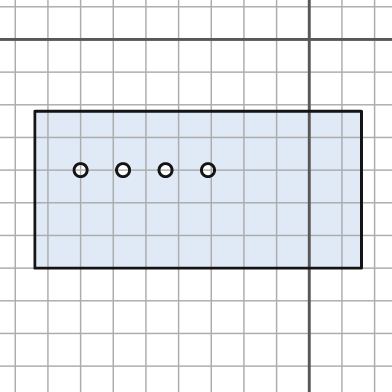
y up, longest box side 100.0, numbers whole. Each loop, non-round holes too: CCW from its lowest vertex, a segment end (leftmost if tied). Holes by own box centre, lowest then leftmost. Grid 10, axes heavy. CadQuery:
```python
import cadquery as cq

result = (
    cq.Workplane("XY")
    .moveTo(-84.0, -70.0)
    .lineTo(16.0, -70.0)
    .lineTo(16.0, -22.0)
    .lineTo(-84.0, -22.0)
    .close()
    .moveTo(-70.0, -40.0)
    .circle(2.0)
    .moveTo(-57.0, -40.0)
    .circle(2.0)
    .moveTo(-44.0, -40.0)
    .circle(2.0)
    .moveTo(-31.0, -40.0)
    .circle(2.0)
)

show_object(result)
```